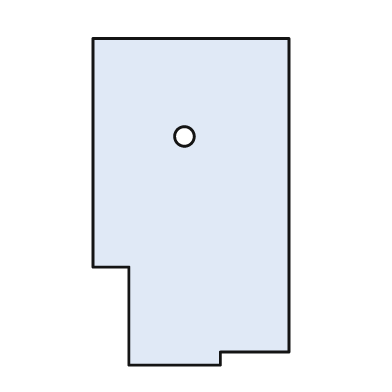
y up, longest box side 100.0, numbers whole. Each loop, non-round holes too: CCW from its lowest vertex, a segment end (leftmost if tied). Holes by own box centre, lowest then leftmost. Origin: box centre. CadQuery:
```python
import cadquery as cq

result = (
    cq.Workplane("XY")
    .moveTo(-19.0, -50.0)
    .lineTo(9.0, -50.0)
    .lineTo(9.0, -46.0)
    .lineTo(30.0, -46.0)
    .lineTo(30.0, 50.0)
    .lineTo(-30.0, 50.0)
    .lineTo(-30.0, -20.0)
    .lineTo(-19.0, -20.0)
    .close()
    .moveTo(-2.0, 20.0)
    .circle(3.0)
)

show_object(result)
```